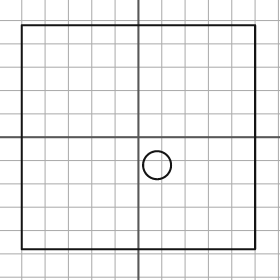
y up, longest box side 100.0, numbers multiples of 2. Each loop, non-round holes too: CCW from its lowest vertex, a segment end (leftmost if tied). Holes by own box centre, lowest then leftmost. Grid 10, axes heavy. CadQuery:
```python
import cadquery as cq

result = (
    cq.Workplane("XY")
    .moveTo(-50.0, -48.0)
    .lineTo(50.0, -48.0)
    .lineTo(50.0, 48.0)
    .lineTo(-50.0, 48.0)
    .close()
    .moveTo(8.0, -12.0)
    .circle(6.0)
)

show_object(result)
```